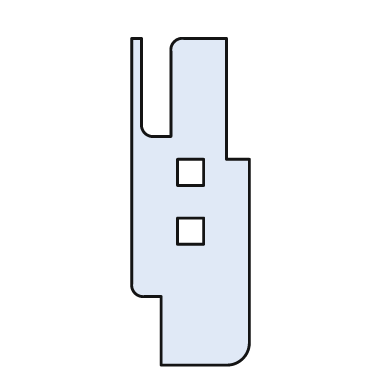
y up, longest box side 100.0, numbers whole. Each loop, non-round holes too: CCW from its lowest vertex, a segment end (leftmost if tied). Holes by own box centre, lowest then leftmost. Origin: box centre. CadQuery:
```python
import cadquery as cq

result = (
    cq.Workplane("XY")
    .moveTo(-9.0, -50.0)
    .lineTo(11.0, -50.0)
    .threePointArc((16.0, -48.0), (18.0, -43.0))
    .lineTo(18.0, 13.0)
    .lineTo(11.0, 13.0)
    .lineTo(11.0, 50.0)
    .lineTo(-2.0, 50.0)
    .threePointArc((-5.0, 49.0), (-6.0, 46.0))
    .lineTo(-6.0, 20.0)
    .lineTo(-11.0, 20.0)
    .threePointArc((-14.0, 21.0), (-15.0, 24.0))
    .lineTo(-15.0, 50.0)
    .lineTo(-18.0, 50.0)
    .lineTo(-18.0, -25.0)
    .threePointArc((-17.0, -28.0), (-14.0, -29.0))
    .lineTo(-9.0, -29.0)
    .close()
    .moveTo(-4.0, -13.0)
    .lineTo(4.0, -13.0)
    .lineTo(4.0, -5.0)
    .lineTo(-4.0, -5.0)
    .close()
    .moveTo(-4.0, 5.0)
    .lineTo(4.0, 5.0)
    .lineTo(4.0, 13.0)
    .lineTo(-4.0, 13.0)
    .close()
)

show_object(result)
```